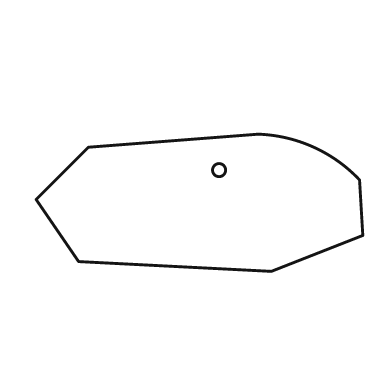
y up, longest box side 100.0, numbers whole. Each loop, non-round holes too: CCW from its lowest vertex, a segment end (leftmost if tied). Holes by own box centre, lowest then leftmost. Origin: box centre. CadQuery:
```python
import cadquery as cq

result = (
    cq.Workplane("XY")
    .moveTo(22.0, -21.0)
    .lineTo(50.0, -10.0)
    .lineTo(49.0, 7.0)
    .threePointArc((35.0, 17.0), (18.0, 21.0))
    .lineTo(-34.0, 17.0)
    .lineTo(-50.0, 1.0)
    .lineTo(-37.0, -18.0)
    .close()
    .moveTo(6.0, 10.0)
    .circle(2.0)
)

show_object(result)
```